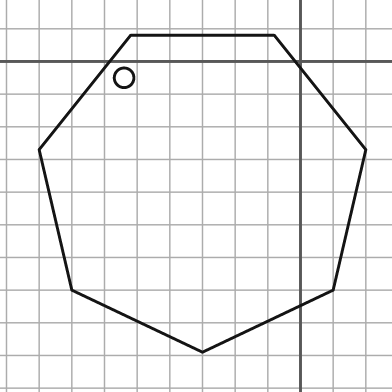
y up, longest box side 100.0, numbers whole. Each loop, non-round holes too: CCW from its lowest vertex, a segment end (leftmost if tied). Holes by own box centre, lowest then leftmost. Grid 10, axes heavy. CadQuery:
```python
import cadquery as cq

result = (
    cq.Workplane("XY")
    .moveTo(-30.0, -89.0)
    .lineTo(10.0, -70.0)
    .lineTo(20.0, -27.0)
    .lineTo(-8.0, 8.0)
    .lineTo(-52.0, 8.0)
    .lineTo(-80.0, -27.0)
    .lineTo(-70.0, -70.0)
    .close()
    .moveTo(-54.0, -5.0)
    .circle(3.0)
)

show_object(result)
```